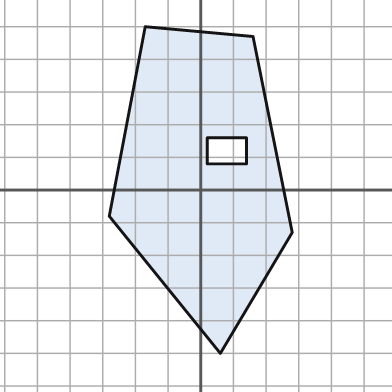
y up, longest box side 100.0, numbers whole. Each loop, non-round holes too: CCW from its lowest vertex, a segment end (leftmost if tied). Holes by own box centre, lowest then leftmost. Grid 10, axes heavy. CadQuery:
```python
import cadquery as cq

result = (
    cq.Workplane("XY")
    .moveTo(6.0, -50.0)
    .lineTo(28.0, -13.0)
    .lineTo(16.0, 47.0)
    .lineTo(-17.0, 50.0)
    .lineTo(-28.0, -8.0)
    .close()
    .moveTo(2.0, 8.0)
    .lineTo(14.0, 8.0)
    .lineTo(14.0, 16.0)
    .lineTo(2.0, 16.0)
    .close()
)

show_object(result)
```